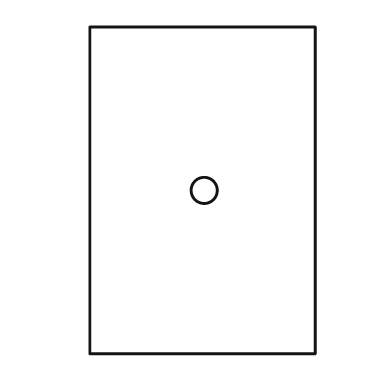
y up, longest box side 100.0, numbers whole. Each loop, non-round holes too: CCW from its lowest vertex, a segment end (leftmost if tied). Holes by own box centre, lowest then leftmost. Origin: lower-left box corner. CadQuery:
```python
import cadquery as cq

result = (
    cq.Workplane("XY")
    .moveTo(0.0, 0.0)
    .lineTo(69.0, 0.0)
    .lineTo(69.0, 100.0)
    .lineTo(0.0, 100.0)
    .close()
    .moveTo(35.0, 50.0)
    .circle(4.0)
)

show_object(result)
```